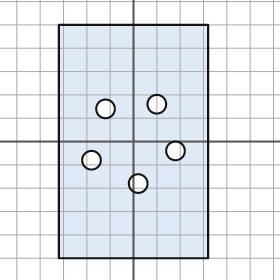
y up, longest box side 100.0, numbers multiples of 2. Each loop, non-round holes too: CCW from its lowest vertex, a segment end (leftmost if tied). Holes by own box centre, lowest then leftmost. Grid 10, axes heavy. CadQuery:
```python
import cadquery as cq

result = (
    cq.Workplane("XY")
    .moveTo(-32.0, -50.0)
    .lineTo(32.0, -50.0)
    .lineTo(32.0, 50.0)
    .lineTo(-32.0, 50.0)
    .close()
    .moveTo(2.0, -18.0)
    .circle(4.0)
    .moveTo(-18.0, -8.0)
    .circle(4.0)
    .moveTo(18.0, -4.0)
    .circle(4.0)
    .moveTo(-12.0, 14.0)
    .circle(4.0)
    .moveTo(10.0, 16.0)
    .circle(4.0)
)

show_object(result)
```